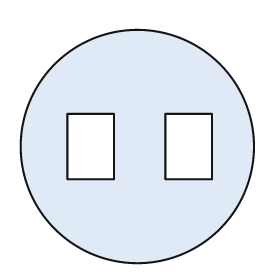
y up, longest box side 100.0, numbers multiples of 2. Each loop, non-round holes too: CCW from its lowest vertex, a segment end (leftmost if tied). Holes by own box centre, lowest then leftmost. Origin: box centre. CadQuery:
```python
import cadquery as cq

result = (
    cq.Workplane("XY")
    .moveTo(0.0, 0.0)
    .circle(50.0)
    .moveTo(-30.0, -14.0)
    .lineTo(-10.0, -14.0)
    .lineTo(-10.0, 14.0)
    .lineTo(-30.0, 14.0)
    .close()
    .moveTo(12.0, -14.0)
    .lineTo(32.0, -14.0)
    .lineTo(32.0, 14.0)
    .lineTo(12.0, 14.0)
    .close()
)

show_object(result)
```